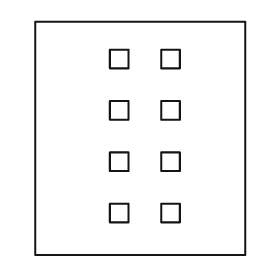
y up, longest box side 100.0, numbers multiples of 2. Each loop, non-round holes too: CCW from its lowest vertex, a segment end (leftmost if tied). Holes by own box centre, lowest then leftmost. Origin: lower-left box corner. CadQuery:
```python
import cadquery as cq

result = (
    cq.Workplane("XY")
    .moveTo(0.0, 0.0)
    .lineTo(90.0, 0.0)
    .lineTo(90.0, 100.0)
    .lineTo(0.0, 100.0)
    .close()
    .moveTo(32.0, 14.0)
    .lineTo(40.0, 14.0)
    .lineTo(40.0, 22.0)
    .lineTo(32.0, 22.0)
    .close()
    .moveTo(54.0, 14.0)
    .lineTo(62.0, 14.0)
    .lineTo(62.0, 22.0)
    .lineTo(54.0, 22.0)
    .close()
    .moveTo(32.0, 36.0)
    .lineTo(40.0, 36.0)
    .lineTo(40.0, 44.0)
    .lineTo(32.0, 44.0)
    .close()
    .moveTo(54.0, 36.0)
    .lineTo(62.0, 36.0)
    .lineTo(62.0, 44.0)
    .lineTo(54.0, 44.0)
    .close()
    .moveTo(32.0, 58.0)
    .lineTo(40.0, 58.0)
    .lineTo(40.0, 66.0)
    .lineTo(32.0, 66.0)
    .close()
    .moveTo(54.0, 58.0)
    .lineTo(62.0, 58.0)
    .lineTo(62.0, 66.0)
    .lineTo(54.0, 66.0)
    .close()
    .moveTo(32.0, 80.0)
    .lineTo(40.0, 80.0)
    .lineTo(40.0, 88.0)
    .lineTo(32.0, 88.0)
    .close()
    .moveTo(54.0, 80.0)
    .lineTo(62.0, 80.0)
    .lineTo(62.0, 88.0)
    .lineTo(54.0, 88.0)
    .close()
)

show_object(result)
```